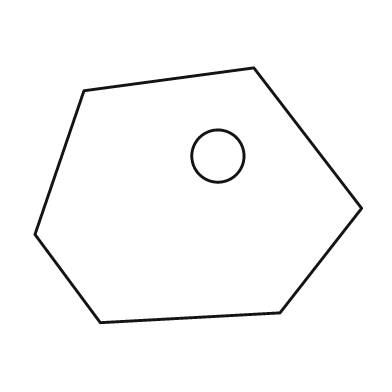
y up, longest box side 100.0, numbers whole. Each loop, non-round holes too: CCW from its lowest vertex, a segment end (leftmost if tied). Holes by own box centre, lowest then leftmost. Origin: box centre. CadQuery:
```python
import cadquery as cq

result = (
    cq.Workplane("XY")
    .moveTo(-30.0, -39.0)
    .lineTo(25.0, -36.0)
    .lineTo(50.0, -4.0)
    .lineTo(17.0, 39.0)
    .lineTo(-35.0, 32.0)
    .lineTo(-50.0, -12.0)
    .close()
    .moveTo(6.0, 12.0)
    .circle(8.0)
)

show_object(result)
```